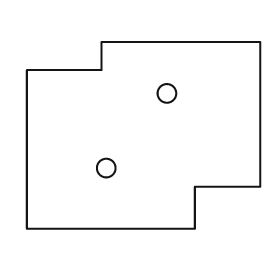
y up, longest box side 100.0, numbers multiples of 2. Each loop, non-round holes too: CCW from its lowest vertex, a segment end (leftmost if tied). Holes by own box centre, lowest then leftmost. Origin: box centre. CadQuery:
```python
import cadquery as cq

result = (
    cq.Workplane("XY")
    .moveTo(-50.0, -40.0)
    .lineTo(22.0, -40.0)
    .lineTo(22.0, -22.0)
    .lineTo(50.0, -22.0)
    .lineTo(50.0, 40.0)
    .lineTo(-18.0, 40.0)
    .lineTo(-18.0, 28.0)
    .lineTo(-50.0, 28.0)
    .close()
    .moveTo(-16.0, -14.0)
    .circle(4.0)
    .moveTo(10.0, 18.0)
    .circle(4.0)
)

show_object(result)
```